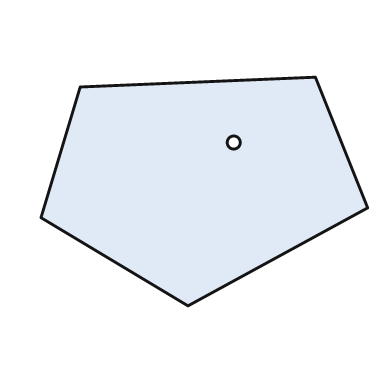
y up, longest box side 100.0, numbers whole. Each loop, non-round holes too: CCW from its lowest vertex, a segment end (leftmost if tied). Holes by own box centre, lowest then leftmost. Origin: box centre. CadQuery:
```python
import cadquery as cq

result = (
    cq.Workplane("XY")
    .moveTo(-5.0, -35.0)
    .lineTo(50.0, -5.0)
    .lineTo(34.0, 35.0)
    .lineTo(-38.0, 32.0)
    .lineTo(-50.0, -8.0)
    .close()
    .moveTo(9.0, 15.0)
    .circle(2.0)
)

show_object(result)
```